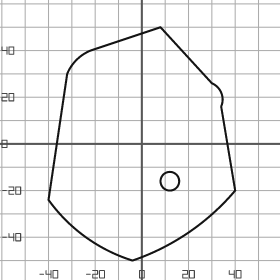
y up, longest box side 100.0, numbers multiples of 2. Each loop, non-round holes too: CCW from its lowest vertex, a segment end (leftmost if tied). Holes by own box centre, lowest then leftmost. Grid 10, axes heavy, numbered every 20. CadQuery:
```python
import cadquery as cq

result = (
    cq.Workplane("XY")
    .moveTo(-4.0, -50.0)
    .threePointArc((20.0, -38.0), (40.0, -20.0))
    .lineTo(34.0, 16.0)
    .threePointArc((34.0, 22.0), (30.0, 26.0))
    .lineTo(8.0, 50.0)
    .lineTo(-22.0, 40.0)
    .threePointArc((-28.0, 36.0), (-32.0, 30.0))
    .lineTo(-40.0, -24.0)
    .threePointArc((-24.0, -40.0), (-4.0, -50.0))
    .close()
    .moveTo(12.0, -16.0)
    .circle(4.0)
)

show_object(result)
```